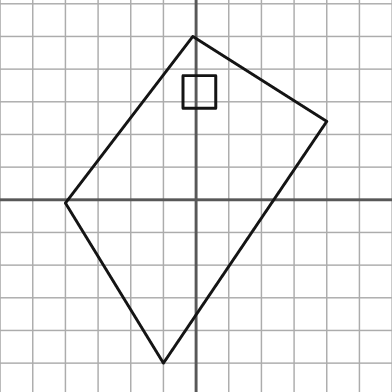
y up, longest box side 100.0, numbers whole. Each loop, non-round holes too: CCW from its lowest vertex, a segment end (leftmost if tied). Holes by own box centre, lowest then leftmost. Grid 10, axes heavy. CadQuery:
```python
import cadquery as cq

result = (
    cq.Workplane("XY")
    .moveTo(-10.0, -50.0)
    .lineTo(40.0, 24.0)
    .lineTo(-1.0, 50.0)
    .lineTo(-40.0, -1.0)
    .close()
    .moveTo(-4.0, 28.0)
    .lineTo(6.0, 28.0)
    .lineTo(6.0, 38.0)
    .lineTo(-4.0, 38.0)
    .close()
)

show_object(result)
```